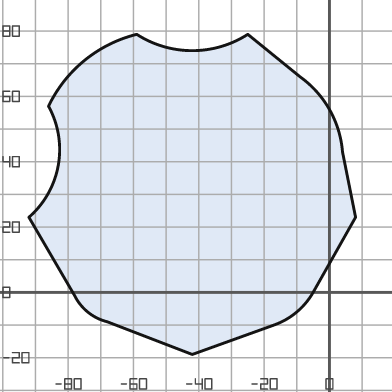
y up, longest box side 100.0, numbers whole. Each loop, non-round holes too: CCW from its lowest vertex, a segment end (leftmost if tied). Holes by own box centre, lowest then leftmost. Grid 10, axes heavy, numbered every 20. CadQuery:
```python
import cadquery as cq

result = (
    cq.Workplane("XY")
    .moveTo(-42.0, -19.0)
    .lineTo(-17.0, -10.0)
    .threePointArc((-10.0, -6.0), (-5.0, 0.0))
    .lineTo(8.0, 23.0)
    .lineTo(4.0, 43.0)
    .threePointArc((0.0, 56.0), (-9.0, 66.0))
    .lineTo(-25.0, 79.0)
    .threePointArc((-42.0, 74.0), (-59.0, 79.0))
    .threePointArc((-75.0, 71.0), (-86.0, 57.0))
    .threePointArc((-83.0, 39.0), (-92.0, 23.0))
    .lineTo(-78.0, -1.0)
    .threePointArc((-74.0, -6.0), (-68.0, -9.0))
    .close()
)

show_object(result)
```